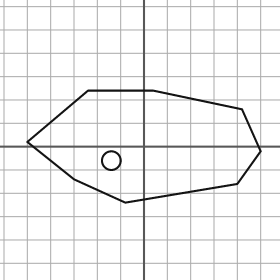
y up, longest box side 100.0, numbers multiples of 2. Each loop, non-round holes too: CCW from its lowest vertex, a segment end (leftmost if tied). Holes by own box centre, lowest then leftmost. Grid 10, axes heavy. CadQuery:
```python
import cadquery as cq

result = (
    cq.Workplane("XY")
    .moveTo(-8.0, -24.0)
    .lineTo(40.0, -16.0)
    .lineTo(50.0, -2.0)
    .lineTo(42.0, 16.0)
    .lineTo(4.0, 24.0)
    .lineTo(-24.0, 24.0)
    .lineTo(-50.0, 2.0)
    .lineTo(-30.0, -14.0)
    .close()
    .moveTo(-14.0, -6.0)
    .circle(4.0)
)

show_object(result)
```